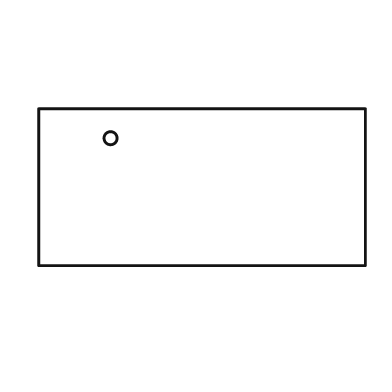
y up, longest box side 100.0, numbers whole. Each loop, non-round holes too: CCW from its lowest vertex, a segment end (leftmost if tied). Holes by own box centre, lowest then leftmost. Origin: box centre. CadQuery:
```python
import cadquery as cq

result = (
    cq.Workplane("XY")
    .moveTo(-50.0, -24.0)
    .lineTo(50.0, -24.0)
    .lineTo(50.0, 24.0)
    .lineTo(-50.0, 24.0)
    .close()
    .moveTo(-28.0, 15.0)
    .circle(2.0)
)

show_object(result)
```